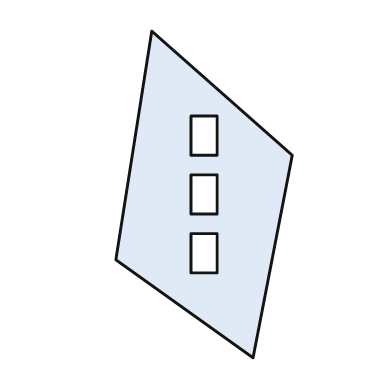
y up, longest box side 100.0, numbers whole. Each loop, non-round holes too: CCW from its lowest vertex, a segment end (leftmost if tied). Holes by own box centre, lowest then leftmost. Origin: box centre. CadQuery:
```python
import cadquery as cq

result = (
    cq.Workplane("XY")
    .moveTo(15.0, -50.0)
    .lineTo(27.0, 12.0)
    .lineTo(-16.0, 50.0)
    .lineTo(-27.0, -20.0)
    .close()
    .moveTo(-4.0, -24.0)
    .lineTo(4.0, -24.0)
    .lineTo(4.0, -12.0)
    .lineTo(-4.0, -12.0)
    .close()
    .moveTo(-4.0, -6.0)
    .lineTo(4.0, -6.0)
    .lineTo(4.0, 6.0)
    .lineTo(-4.0, 6.0)
    .close()
    .moveTo(-4.0, 12.0)
    .lineTo(4.0, 12.0)
    .lineTo(4.0, 24.0)
    .lineTo(-4.0, 24.0)
    .close()
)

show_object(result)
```